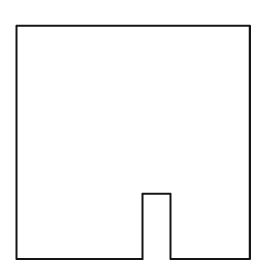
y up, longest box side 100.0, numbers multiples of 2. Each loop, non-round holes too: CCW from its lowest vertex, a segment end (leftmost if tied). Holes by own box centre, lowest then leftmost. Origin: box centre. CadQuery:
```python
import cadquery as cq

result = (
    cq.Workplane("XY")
    .moveTo(-50.0, -50.0)
    .lineTo(4.0, -50.0)
    .lineTo(4.0, -22.0)
    .lineTo(16.0, -22.0)
    .lineTo(16.0, -50.0)
    .lineTo(50.0, -50.0)
    .lineTo(50.0, 50.0)
    .lineTo(-50.0, 50.0)
    .close()
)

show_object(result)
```